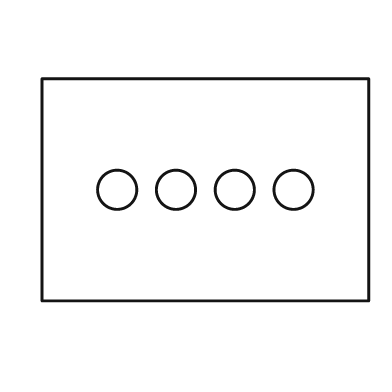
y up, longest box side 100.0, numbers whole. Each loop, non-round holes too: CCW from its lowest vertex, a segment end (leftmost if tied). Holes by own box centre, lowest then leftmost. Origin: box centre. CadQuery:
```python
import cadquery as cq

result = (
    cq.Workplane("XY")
    .moveTo(-50.0, -34.0)
    .lineTo(50.0, -34.0)
    .lineTo(50.0, 34.0)
    .lineTo(-50.0, 34.0)
    .close()
    .moveTo(-27.0, 0.0)
    .circle(6.0)
    .moveTo(-9.0, 0.0)
    .circle(6.0)
    .moveTo(9.0, 0.0)
    .circle(6.0)
    .moveTo(27.0, 0.0)
    .circle(6.0)
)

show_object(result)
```